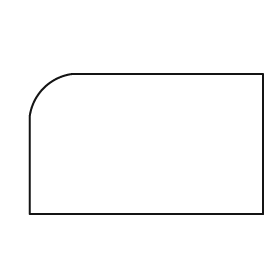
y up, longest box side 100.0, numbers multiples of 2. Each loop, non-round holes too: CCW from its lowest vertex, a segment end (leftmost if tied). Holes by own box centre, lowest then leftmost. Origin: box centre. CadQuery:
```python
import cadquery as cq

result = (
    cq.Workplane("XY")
    .moveTo(-50.0, -30.0)
    .lineTo(50.0, -30.0)
    .lineTo(50.0, 30.0)
    .lineTo(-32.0, 30.0)
    .threePointArc((-44.0, 24.0), (-50.0, 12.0))
    .close()
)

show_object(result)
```